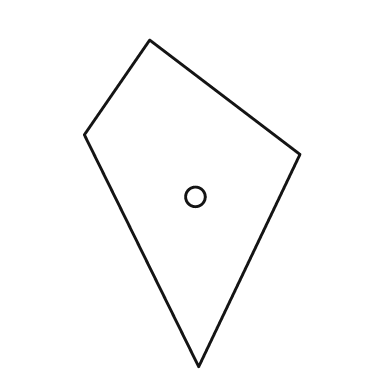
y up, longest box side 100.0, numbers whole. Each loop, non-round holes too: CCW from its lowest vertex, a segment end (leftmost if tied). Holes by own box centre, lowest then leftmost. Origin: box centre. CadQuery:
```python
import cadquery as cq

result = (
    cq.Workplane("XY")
    .moveTo(2.0, -50.0)
    .lineTo(33.0, 15.0)
    .lineTo(-13.0, 50.0)
    .lineTo(-33.0, 21.0)
    .close()
    .moveTo(1.0, 2.0)
    .circle(3.0)
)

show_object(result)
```